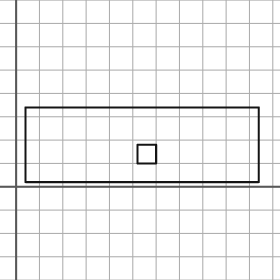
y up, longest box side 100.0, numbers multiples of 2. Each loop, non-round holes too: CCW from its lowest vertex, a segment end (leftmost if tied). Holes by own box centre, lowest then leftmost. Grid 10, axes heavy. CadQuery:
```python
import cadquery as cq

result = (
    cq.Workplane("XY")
    .moveTo(4.0, 2.0)
    .lineTo(104.0, 2.0)
    .lineTo(104.0, 34.0)
    .lineTo(4.0, 34.0)
    .close()
    .moveTo(52.0, 10.0)
    .lineTo(60.0, 10.0)
    .lineTo(60.0, 18.0)
    .lineTo(52.0, 18.0)
    .close()
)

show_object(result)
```